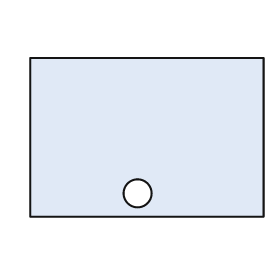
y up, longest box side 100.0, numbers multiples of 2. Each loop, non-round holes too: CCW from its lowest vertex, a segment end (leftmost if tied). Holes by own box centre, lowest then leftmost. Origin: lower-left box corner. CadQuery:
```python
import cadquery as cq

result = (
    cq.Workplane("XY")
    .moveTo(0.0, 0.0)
    .lineTo(100.0, 0.0)
    .lineTo(100.0, 68.0)
    .lineTo(0.0, 68.0)
    .close()
    .moveTo(46.0, 10.0)
    .circle(6.0)
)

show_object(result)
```